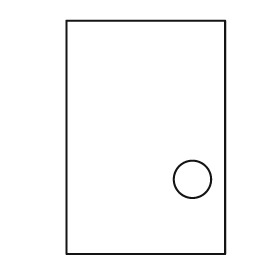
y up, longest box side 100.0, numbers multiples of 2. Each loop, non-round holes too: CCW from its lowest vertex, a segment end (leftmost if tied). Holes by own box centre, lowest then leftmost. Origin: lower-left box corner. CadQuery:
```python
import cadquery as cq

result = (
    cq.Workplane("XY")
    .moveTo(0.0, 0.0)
    .lineTo(68.0, 0.0)
    .lineTo(68.0, 100.0)
    .lineTo(0.0, 100.0)
    .close()
    .moveTo(54.0, 32.0)
    .circle(8.0)
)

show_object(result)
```